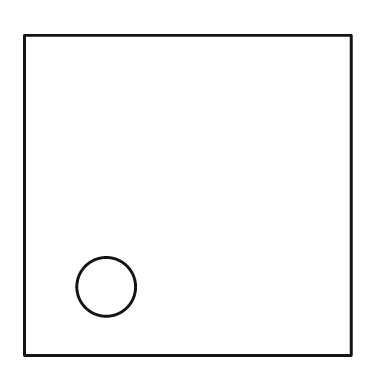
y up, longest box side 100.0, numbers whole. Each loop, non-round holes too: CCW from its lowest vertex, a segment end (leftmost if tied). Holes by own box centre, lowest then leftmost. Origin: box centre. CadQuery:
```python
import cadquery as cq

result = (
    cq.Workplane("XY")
    .moveTo(-50.0, -49.0)
    .lineTo(50.0, -49.0)
    .lineTo(50.0, 49.0)
    .lineTo(-50.0, 49.0)
    .close()
    .moveTo(-25.0, -28.0)
    .circle(9.0)
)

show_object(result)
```